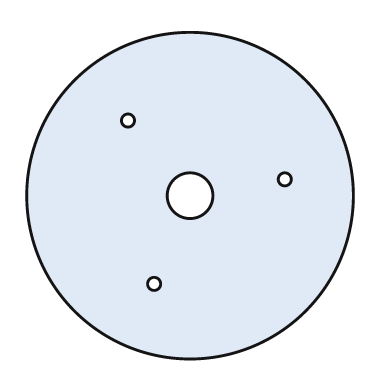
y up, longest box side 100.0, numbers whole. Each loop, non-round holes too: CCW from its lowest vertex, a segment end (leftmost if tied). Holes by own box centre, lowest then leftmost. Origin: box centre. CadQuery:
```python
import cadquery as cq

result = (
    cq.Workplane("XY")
    .moveTo(0.0, 0.0)
    .circle(50.0)
    .moveTo(-11.0, -27.0)
    .circle(2.0)
    .moveTo(0.0, 0.0)
    .circle(7.0)
    .moveTo(29.0, 5.0)
    .circle(2.0)
    .moveTo(-19.0, 23.0)
    .circle(2.0)
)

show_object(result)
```